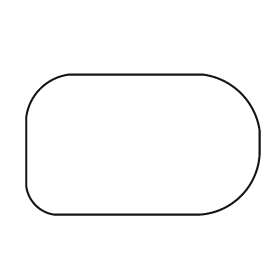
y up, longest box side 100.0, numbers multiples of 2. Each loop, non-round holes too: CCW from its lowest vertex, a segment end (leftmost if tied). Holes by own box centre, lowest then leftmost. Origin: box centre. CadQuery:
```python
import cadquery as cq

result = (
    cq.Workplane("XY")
    .moveTo(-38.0, -30.0)
    .lineTo(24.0, -30.0)
    .threePointArc((42.0, -22.0), (50.0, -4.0))
    .lineTo(50.0, 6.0)
    .threePointArc((42.0, 22.0), (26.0, 30.0))
    .lineTo(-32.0, 30.0)
    .threePointArc((-44.0, 24.0), (-50.0, 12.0))
    .lineTo(-50.0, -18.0)
    .threePointArc((-46.0, -26.0), (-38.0, -30.0))
    .close()
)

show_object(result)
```